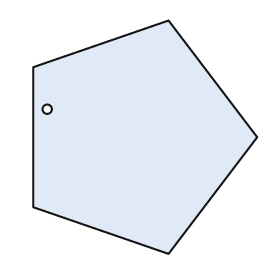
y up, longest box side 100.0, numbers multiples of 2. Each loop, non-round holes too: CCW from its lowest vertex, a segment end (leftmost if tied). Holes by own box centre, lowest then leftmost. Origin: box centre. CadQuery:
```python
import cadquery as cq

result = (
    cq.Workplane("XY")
    .moveTo(10.0, -50.0)
    .lineTo(48.0, 0.0)
    .lineTo(10.0, 50.0)
    .lineTo(-48.0, 30.0)
    .lineTo(-48.0, -30.0)
    .close()
    .moveTo(-42.0, 12.0)
    .circle(2.0)
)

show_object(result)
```